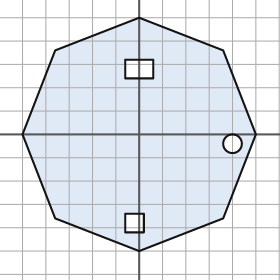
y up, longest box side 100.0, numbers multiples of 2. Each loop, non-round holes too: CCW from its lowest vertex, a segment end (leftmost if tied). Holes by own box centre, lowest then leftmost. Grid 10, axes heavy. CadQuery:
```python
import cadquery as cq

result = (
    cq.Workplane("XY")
    .moveTo(0.0, -50.0)
    .lineTo(36.0, -36.0)
    .lineTo(50.0, 0.0)
    .lineTo(36.0, 36.0)
    .lineTo(0.0, 50.0)
    .lineTo(-36.0, 36.0)
    .lineTo(-50.0, 0.0)
    .lineTo(-36.0, -36.0)
    .close()
    .moveTo(-6.0, -42.0)
    .lineTo(2.0, -42.0)
    .lineTo(2.0, -34.0)
    .lineTo(-6.0, -34.0)
    .close()
    .moveTo(40.0, -4.0)
    .circle(4.0)
    .moveTo(-6.0, 24.0)
    .lineTo(6.0, 24.0)
    .lineTo(6.0, 32.0)
    .lineTo(-6.0, 32.0)
    .close()
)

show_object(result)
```